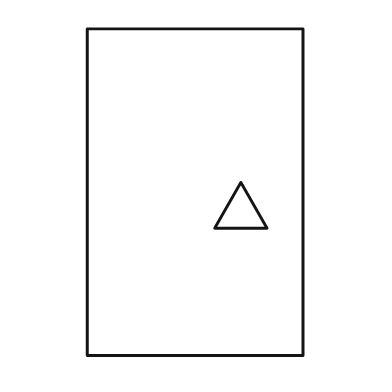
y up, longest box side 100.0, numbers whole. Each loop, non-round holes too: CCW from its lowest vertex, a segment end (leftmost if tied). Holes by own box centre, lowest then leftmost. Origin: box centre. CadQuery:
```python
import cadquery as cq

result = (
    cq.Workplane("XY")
    .moveTo(-33.0, -50.0)
    .lineTo(33.0, -50.0)
    .lineTo(33.0, 50.0)
    .lineTo(-33.0, 50.0)
    .close()
    .moveTo(6.0, -11.0)
    .lineTo(22.0, -11.0)
    .lineTo(14.0, 3.0)
    .close()
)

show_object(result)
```